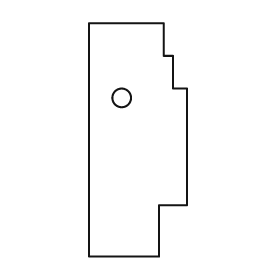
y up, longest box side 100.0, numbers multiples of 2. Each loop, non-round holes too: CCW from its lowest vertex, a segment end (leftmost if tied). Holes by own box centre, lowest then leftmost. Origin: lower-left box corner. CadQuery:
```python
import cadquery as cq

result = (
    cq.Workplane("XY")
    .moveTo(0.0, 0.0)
    .lineTo(30.0, 0.0)
    .lineTo(30.0, 22.0)
    .lineTo(42.0, 22.0)
    .lineTo(42.0, 72.0)
    .lineTo(36.0, 72.0)
    .lineTo(36.0, 86.0)
    .lineTo(32.0, 86.0)
    .lineTo(32.0, 100.0)
    .lineTo(0.0, 100.0)
    .close()
    .moveTo(14.0, 68.0)
    .circle(4.0)
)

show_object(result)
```